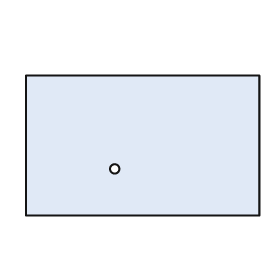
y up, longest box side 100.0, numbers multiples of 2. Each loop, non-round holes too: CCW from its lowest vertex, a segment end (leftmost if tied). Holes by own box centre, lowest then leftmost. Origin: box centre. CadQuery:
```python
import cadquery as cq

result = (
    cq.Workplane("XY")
    .moveTo(-50.0, -30.0)
    .lineTo(50.0, -30.0)
    .lineTo(50.0, 30.0)
    .lineTo(-50.0, 30.0)
    .close()
    .moveTo(-12.0, -10.0)
    .circle(2.0)
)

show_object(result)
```